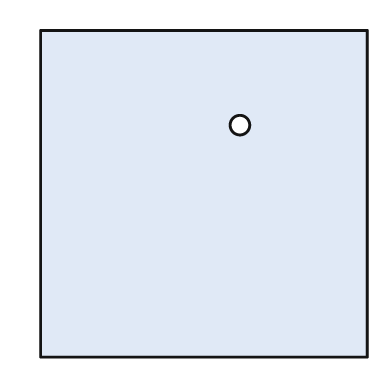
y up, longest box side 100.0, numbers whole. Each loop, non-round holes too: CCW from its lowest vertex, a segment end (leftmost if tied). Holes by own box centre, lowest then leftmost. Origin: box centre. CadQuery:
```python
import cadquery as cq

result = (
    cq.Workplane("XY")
    .moveTo(-50.0, -50.0)
    .lineTo(50.0, -50.0)
    .lineTo(50.0, 50.0)
    .lineTo(-50.0, 50.0)
    .close()
    .moveTo(11.0, 21.0)
    .circle(3.0)
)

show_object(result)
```